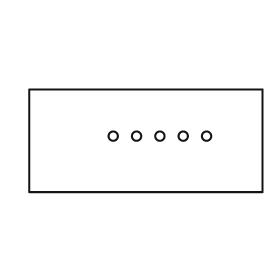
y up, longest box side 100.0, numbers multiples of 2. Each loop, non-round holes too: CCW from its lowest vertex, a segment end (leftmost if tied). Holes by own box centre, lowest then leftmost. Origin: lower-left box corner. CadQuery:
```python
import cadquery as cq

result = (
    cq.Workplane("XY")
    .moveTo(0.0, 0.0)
    .lineTo(100.0, 0.0)
    .lineTo(100.0, 44.0)
    .lineTo(0.0, 44.0)
    .close()
    .moveTo(36.0, 24.0)
    .circle(2.0)
    .moveTo(46.0, 24.0)
    .circle(2.0)
    .moveTo(56.0, 24.0)
    .circle(2.0)
    .moveTo(66.0, 24.0)
    .circle(2.0)
    .moveTo(76.0, 24.0)
    .circle(2.0)
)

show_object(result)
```